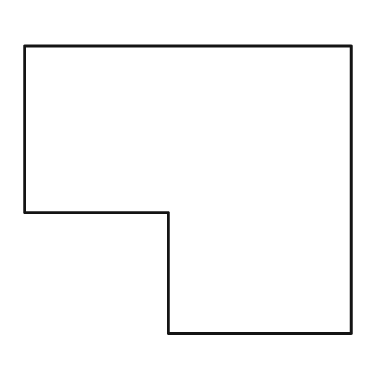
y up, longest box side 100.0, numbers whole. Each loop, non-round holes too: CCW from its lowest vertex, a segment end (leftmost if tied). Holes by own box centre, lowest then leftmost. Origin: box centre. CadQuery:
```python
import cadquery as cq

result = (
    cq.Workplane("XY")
    .moveTo(-6.0, -44.0)
    .lineTo(50.0, -44.0)
    .lineTo(50.0, 44.0)
    .lineTo(-50.0, 44.0)
    .lineTo(-50.0, -7.0)
    .lineTo(-6.0, -7.0)
    .close()
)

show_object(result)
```